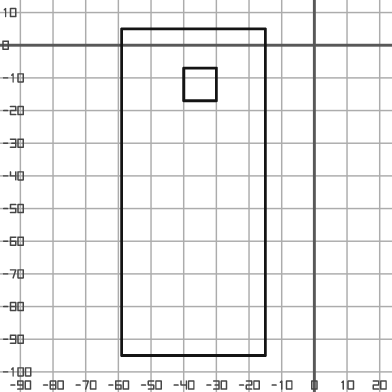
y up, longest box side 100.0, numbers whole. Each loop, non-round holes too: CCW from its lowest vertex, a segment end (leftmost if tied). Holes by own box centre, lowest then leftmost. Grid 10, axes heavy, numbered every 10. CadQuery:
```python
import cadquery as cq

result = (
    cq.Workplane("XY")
    .moveTo(-59.0, -95.0)
    .lineTo(-15.0, -95.0)
    .lineTo(-15.0, 5.0)
    .lineTo(-59.0, 5.0)
    .close()
    .moveTo(-40.0, -17.0)
    .lineTo(-30.0, -17.0)
    .lineTo(-30.0, -7.0)
    .lineTo(-40.0, -7.0)
    .close()
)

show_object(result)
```